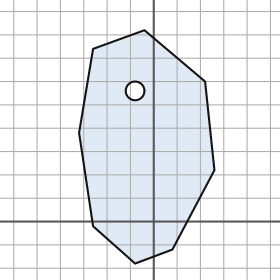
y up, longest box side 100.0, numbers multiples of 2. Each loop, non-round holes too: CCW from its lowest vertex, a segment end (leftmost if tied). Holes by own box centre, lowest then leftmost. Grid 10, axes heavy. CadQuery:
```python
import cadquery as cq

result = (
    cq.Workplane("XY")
    .moveTo(-8.0, -18.0)
    .lineTo(8.0, -12.0)
    .lineTo(26.0, 22.0)
    .lineTo(22.0, 60.0)
    .lineTo(-4.0, 82.0)
    .lineTo(-26.0, 74.0)
    .lineTo(-32.0, 38.0)
    .lineTo(-26.0, -2.0)
    .close()
    .moveTo(-8.0, 56.0)
    .circle(4.0)
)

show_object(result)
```